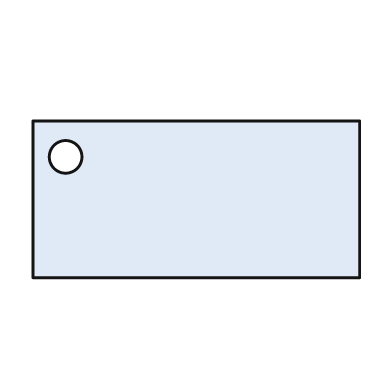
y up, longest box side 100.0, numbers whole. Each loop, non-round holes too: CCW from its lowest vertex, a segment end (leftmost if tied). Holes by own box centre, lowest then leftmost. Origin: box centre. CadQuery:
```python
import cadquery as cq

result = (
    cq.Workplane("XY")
    .moveTo(-50.0, -24.0)
    .lineTo(50.0, -24.0)
    .lineTo(50.0, 24.0)
    .lineTo(-50.0, 24.0)
    .close()
    .moveTo(-40.0, 13.0)
    .circle(5.0)
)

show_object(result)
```